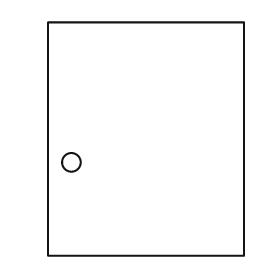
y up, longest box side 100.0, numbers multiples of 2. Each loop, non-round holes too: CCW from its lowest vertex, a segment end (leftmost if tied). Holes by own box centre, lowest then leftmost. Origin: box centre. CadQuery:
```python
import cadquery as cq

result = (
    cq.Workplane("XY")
    .moveTo(-42.0, -50.0)
    .lineTo(42.0, -50.0)
    .lineTo(42.0, 50.0)
    .lineTo(-42.0, 50.0)
    .close()
    .moveTo(-32.0, -10.0)
    .circle(4.0)
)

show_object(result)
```